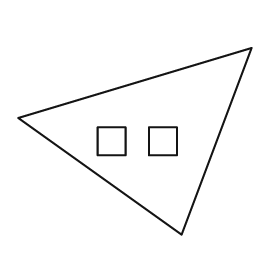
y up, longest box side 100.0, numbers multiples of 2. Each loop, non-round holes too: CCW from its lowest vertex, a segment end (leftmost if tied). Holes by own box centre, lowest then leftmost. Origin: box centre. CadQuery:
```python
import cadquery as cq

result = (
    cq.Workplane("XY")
    .moveTo(20.0, -40.0)
    .lineTo(50.0, 40.0)
    .lineTo(-50.0, 10.0)
    .close()
    .moveTo(-16.0, -6.0)
    .lineTo(-4.0, -6.0)
    .lineTo(-4.0, 6.0)
    .lineTo(-16.0, 6.0)
    .close()
    .moveTo(6.0, -6.0)
    .lineTo(18.0, -6.0)
    .lineTo(18.0, 6.0)
    .lineTo(6.0, 6.0)
    .close()
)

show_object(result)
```